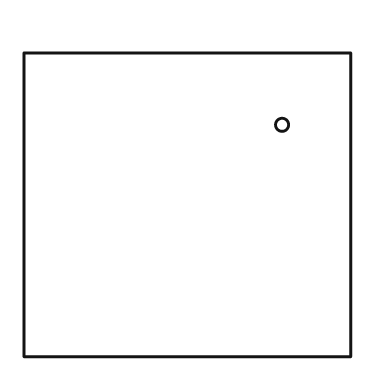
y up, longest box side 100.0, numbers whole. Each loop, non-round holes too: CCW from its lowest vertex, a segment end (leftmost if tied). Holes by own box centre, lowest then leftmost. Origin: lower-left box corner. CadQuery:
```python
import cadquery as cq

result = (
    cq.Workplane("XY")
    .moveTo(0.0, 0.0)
    .lineTo(100.0, 0.0)
    .lineTo(100.0, 93.0)
    .lineTo(0.0, 93.0)
    .close()
    .moveTo(79.0, 71.0)
    .circle(2.0)
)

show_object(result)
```